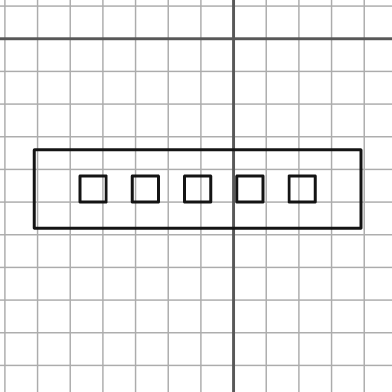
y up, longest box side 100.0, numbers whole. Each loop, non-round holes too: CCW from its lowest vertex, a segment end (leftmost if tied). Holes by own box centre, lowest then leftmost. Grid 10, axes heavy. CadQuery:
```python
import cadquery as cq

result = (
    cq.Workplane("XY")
    .moveTo(-61.0, -58.0)
    .lineTo(39.0, -58.0)
    .lineTo(39.0, -34.0)
    .lineTo(-61.0, -34.0)
    .close()
    .moveTo(-47.0, -50.0)
    .lineTo(-39.0, -50.0)
    .lineTo(-39.0, -42.0)
    .lineTo(-47.0, -42.0)
    .close()
    .moveTo(-31.0, -50.0)
    .lineTo(-23.0, -50.0)
    .lineTo(-23.0, -42.0)
    .lineTo(-31.0, -42.0)
    .close()
    .moveTo(-15.0, -50.0)
    .lineTo(-7.0, -50.0)
    .lineTo(-7.0, -42.0)
    .lineTo(-15.0, -42.0)
    .close()
    .moveTo(1.0, -50.0)
    .lineTo(9.0, -50.0)
    .lineTo(9.0, -42.0)
    .lineTo(1.0, -42.0)
    .close()
    .moveTo(17.0, -50.0)
    .lineTo(25.0, -50.0)
    .lineTo(25.0, -42.0)
    .lineTo(17.0, -42.0)
    .close()
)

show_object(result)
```